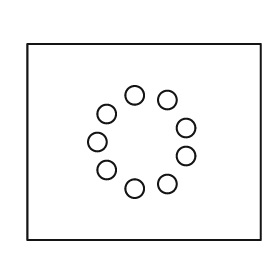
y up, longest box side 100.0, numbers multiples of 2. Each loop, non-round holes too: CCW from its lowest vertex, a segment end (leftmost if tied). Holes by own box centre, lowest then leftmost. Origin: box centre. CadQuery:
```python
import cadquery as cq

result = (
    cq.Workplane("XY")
    .moveTo(-50.0, -42.0)
    .lineTo(50.0, -42.0)
    .lineTo(50.0, 42.0)
    .lineTo(-50.0, 42.0)
    .close()
    .moveTo(-4.0, -20.0)
    .circle(4.0)
    .moveTo(10.0, -18.0)
    .circle(4.0)
    .moveTo(-16.0, -12.0)
    .circle(4.0)
    .moveTo(18.0, -6.0)
    .circle(4.0)
    .moveTo(-20.0, 0.0)
    .circle(4.0)
    .moveTo(18.0, 6.0)
    .circle(4.0)
    .moveTo(-16.0, 12.0)
    .circle(4.0)
    .moveTo(10.0, 18.0)
    .circle(4.0)
    .moveTo(-4.0, 20.0)
    .circle(4.0)
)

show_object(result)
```